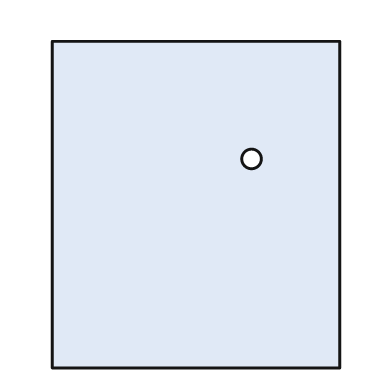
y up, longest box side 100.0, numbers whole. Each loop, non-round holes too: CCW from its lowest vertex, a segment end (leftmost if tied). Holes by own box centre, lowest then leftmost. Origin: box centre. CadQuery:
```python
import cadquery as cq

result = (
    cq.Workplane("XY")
    .moveTo(-44.0, -50.0)
    .lineTo(44.0, -50.0)
    .lineTo(44.0, 50.0)
    .lineTo(-44.0, 50.0)
    .close()
    .moveTo(17.0, 14.0)
    .circle(3.0)
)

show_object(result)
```